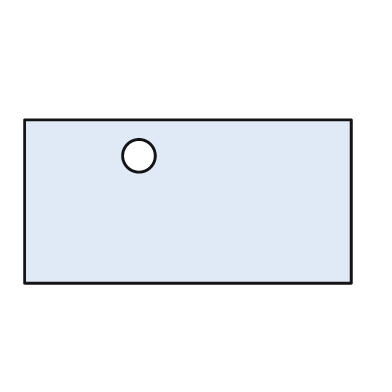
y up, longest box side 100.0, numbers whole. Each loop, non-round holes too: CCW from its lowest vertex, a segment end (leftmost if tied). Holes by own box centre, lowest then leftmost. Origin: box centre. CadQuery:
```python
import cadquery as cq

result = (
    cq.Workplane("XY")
    .moveTo(-50.0, -25.0)
    .lineTo(50.0, -25.0)
    .lineTo(50.0, 25.0)
    .lineTo(-50.0, 25.0)
    .close()
    .moveTo(-15.0, 14.0)
    .circle(5.0)
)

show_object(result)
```